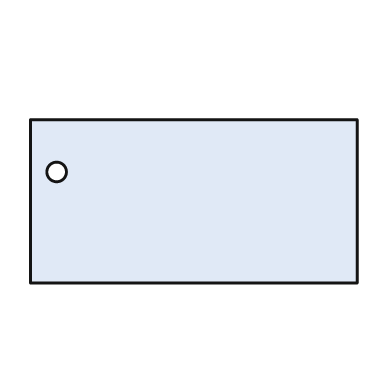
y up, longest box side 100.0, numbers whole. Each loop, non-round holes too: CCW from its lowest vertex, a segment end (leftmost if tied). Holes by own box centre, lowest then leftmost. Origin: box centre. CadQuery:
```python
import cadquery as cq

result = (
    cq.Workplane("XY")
    .moveTo(-50.0, -25.0)
    .lineTo(50.0, -25.0)
    .lineTo(50.0, 25.0)
    .lineTo(-50.0, 25.0)
    .close()
    .moveTo(-42.0, 9.0)
    .circle(3.0)
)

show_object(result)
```